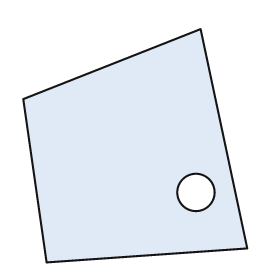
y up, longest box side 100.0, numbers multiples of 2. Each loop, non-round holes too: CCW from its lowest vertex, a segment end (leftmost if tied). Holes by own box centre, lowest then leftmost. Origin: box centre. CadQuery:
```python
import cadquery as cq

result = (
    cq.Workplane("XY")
    .moveTo(-38.0, -50.0)
    .lineTo(48.0, -44.0)
    .lineTo(28.0, 50.0)
    .lineTo(-48.0, 20.0)
    .close()
    .moveTo(26.0, -20.0)
    .circle(8.0)
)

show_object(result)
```